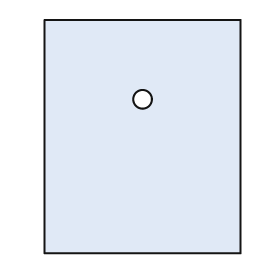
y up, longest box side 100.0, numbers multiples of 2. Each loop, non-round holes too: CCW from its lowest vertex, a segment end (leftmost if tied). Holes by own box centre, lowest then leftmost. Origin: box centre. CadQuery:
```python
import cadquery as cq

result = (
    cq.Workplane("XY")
    .moveTo(-42.0, -50.0)
    .lineTo(42.0, -50.0)
    .lineTo(42.0, 50.0)
    .lineTo(-42.0, 50.0)
    .close()
    .moveTo(0.0, 16.0)
    .circle(4.0)
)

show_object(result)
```